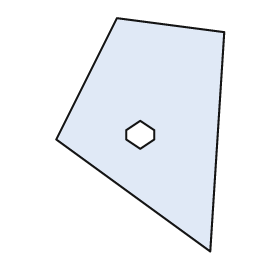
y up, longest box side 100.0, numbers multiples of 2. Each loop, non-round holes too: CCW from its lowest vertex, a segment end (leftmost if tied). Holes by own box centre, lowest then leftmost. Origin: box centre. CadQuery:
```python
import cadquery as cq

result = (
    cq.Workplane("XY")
    .moveTo(30.0, -50.0)
    .lineTo(36.0, 44.0)
    .lineTo(-10.0, 50.0)
    .lineTo(-36.0, -2.0)
    .close()
    .moveTo(0.0, -6.0)
    .lineTo(6.0, -2.0)
    .lineTo(6.0, 2.0)
    .lineTo(0.0, 6.0)
    .lineTo(-6.0, 2.0)
    .lineTo(-6.0, -2.0)
    .close()
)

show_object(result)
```